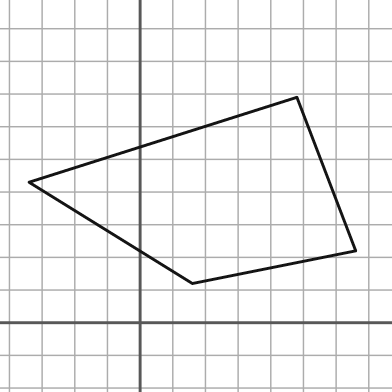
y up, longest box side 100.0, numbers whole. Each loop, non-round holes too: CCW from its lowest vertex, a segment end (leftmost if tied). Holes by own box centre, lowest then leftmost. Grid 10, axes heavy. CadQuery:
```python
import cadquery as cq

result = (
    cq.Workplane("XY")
    .moveTo(16.0, 12.0)
    .lineTo(66.0, 22.0)
    .lineTo(48.0, 69.0)
    .lineTo(-34.0, 43.0)
    .close()
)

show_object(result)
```